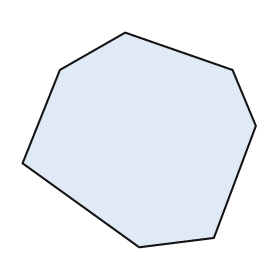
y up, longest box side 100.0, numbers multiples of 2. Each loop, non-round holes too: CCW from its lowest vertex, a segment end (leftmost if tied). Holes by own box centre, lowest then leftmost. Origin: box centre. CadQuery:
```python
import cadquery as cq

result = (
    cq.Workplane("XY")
    .moveTo(0.0, -46.0)
    .lineTo(32.0, -42.0)
    .lineTo(50.0, 6.0)
    .lineTo(40.0, 30.0)
    .lineTo(-6.0, 46.0)
    .lineTo(-34.0, 30.0)
    .lineTo(-50.0, -10.0)
    .close()
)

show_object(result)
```